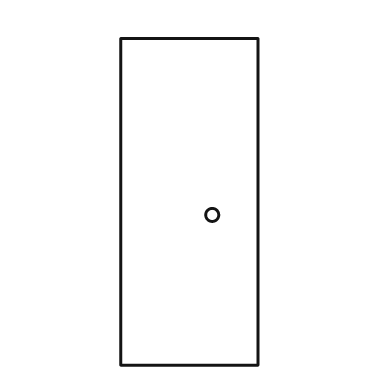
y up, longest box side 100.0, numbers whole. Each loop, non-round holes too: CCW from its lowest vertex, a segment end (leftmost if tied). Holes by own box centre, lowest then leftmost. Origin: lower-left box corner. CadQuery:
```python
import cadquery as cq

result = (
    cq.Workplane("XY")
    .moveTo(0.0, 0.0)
    .lineTo(42.0, 0.0)
    .lineTo(42.0, 100.0)
    .lineTo(0.0, 100.0)
    .close()
    .moveTo(28.0, 46.0)
    .circle(2.0)
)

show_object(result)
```